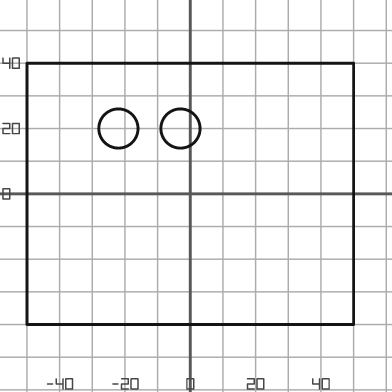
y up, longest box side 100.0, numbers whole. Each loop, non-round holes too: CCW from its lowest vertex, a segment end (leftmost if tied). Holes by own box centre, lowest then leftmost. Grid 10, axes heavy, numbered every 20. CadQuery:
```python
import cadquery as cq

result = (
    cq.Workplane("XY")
    .moveTo(-50.0, -40.0)
    .lineTo(50.0, -40.0)
    .lineTo(50.0, 40.0)
    .lineTo(-50.0, 40.0)
    .close()
    .moveTo(-22.0, 20.0)
    .circle(6.0)
    .moveTo(-3.0, 20.0)
    .circle(6.0)
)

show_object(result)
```